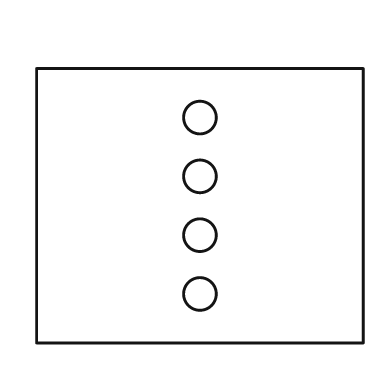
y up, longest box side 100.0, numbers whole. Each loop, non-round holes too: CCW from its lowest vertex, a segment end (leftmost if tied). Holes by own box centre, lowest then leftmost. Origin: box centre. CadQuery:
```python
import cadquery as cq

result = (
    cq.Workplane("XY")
    .moveTo(-50.0, -42.0)
    .lineTo(50.0, -42.0)
    .lineTo(50.0, 42.0)
    .lineTo(-50.0, 42.0)
    .close()
    .moveTo(0.0, -27.0)
    .circle(5.0)
    .moveTo(0.0, -9.0)
    .circle(5.0)
    .moveTo(0.0, 9.0)
    .circle(5.0)
    .moveTo(0.0, 27.0)
    .circle(5.0)
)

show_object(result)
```